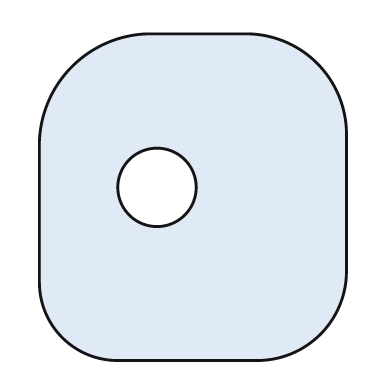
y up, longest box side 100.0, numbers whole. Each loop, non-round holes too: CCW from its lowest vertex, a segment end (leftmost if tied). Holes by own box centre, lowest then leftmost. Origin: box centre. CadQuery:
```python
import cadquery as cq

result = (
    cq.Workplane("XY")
    .moveTo(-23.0, -50.0)
    .lineTo(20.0, -50.0)
    .threePointArc((39.0, -42.0), (47.0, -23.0))
    .lineTo(47.0, 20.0)
    .threePointArc((38.0, 41.0), (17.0, 50.0))
    .lineTo(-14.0, 50.0)
    .threePointArc((-37.0, 40.0), (-47.0, 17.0))
    .lineTo(-47.0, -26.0)
    .threePointArc((-40.0, -43.0), (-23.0, -50.0))
    .close()
    .moveTo(-11.0, 3.0)
    .circle(12.0)
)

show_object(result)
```